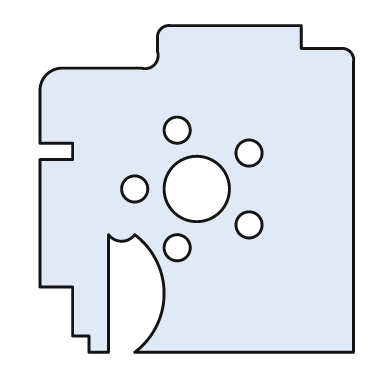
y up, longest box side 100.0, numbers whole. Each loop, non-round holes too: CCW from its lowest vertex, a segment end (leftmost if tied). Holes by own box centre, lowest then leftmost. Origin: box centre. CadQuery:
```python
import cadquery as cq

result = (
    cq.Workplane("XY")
    .moveTo(-33.0, -50.0)
    .lineTo(-27.0, -50.0)
    .lineTo(-27.0, -14.0)
    .threePointArc((-23.0, -16.0), (-19.0, -14.0))
    .threePointArc((-10.0, -32.0), (-19.0, -50.0))
    .lineTo(48.0, -50.0)
    .lineTo(48.0, 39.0)
    .threePointArc((47.0, 42.0), (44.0, 43.0))
    .lineTo(32.0, 43.0)
    .lineTo(32.0, 50.0)
    .lineTo(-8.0, 50.0)
    .threePointArc((-11.0, 49.0), (-12.0, 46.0))
    .lineTo(-12.0, 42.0)
    .threePointArc((-13.0, 38.0), (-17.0, 37.0))
    .lineTo(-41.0, 37.0)
    .threePointArc((-46.0, 35.0), (-48.0, 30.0))
    .lineTo(-48.0, 14.0)
    .lineTo(-38.0, 14.0)
    .lineTo(-38.0, 9.0)
    .lineTo(-48.0, 9.0)
    .lineTo(-48.0, -30.0)
    .lineTo(-38.0, -30.0)
    .lineTo(-38.0, -45.0)
    .lineTo(-33.0, -45.0)
    .close()
    .moveTo(-6.0, -18.0)
    .circle(4.0)
    .moveTo(16.0, -11.0)
    .circle(4.0)
    .moveTo(-19.0, 0.0)
    .circle(4.0)
    .moveTo(0.0, 0.0)
    .circle(10.0)
    .moveTo(16.0, 11.0)
    .circle(4.0)
    .moveTo(-6.0, 18.0)
    .circle(4.0)
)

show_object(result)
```